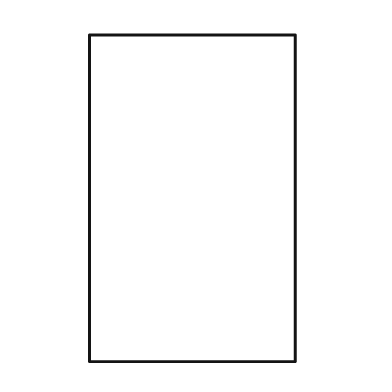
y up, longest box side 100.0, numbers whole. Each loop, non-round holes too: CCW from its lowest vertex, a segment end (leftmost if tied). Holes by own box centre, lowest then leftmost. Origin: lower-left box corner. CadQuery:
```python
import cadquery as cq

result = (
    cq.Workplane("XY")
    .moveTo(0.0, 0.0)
    .lineTo(63.0, 0.0)
    .lineTo(63.0, 100.0)
    .lineTo(0.0, 100.0)
    .close()
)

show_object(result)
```